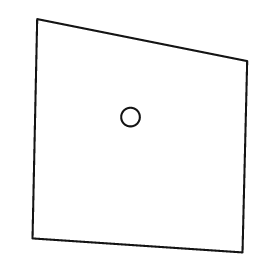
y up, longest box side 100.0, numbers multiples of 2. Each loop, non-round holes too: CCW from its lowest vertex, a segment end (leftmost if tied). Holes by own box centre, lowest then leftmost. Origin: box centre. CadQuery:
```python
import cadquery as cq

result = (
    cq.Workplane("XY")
    .moveTo(44.0, -50.0)
    .lineTo(46.0, 32.0)
    .lineTo(-44.0, 50.0)
    .lineTo(-46.0, -44.0)
    .close()
    .moveTo(-4.0, 8.0)
    .circle(4.0)
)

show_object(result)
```